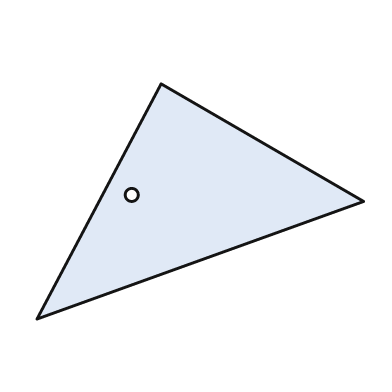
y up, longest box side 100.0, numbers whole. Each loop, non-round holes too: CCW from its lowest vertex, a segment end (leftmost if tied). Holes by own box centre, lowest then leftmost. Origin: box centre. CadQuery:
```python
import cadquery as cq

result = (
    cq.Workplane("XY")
    .moveTo(-50.0, -36.0)
    .lineTo(50.0, 0.0)
    .lineTo(-12.0, 36.0)
    .close()
    .moveTo(-21.0, 2.0)
    .circle(2.0)
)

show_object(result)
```